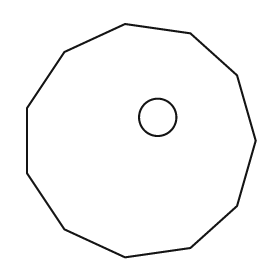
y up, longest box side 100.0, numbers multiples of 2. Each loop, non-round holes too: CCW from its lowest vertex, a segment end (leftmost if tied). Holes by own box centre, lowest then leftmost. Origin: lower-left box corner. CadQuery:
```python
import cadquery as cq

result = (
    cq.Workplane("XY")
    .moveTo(42.0, 0.0)
    .lineTo(70.0, 4.0)
    .lineTo(90.0, 22.0)
    .lineTo(98.0, 50.0)
    .lineTo(90.0, 78.0)
    .lineTo(70.0, 96.0)
    .lineTo(42.0, 100.0)
    .lineTo(16.0, 88.0)
    .lineTo(0.0, 64.0)
    .lineTo(0.0, 36.0)
    .lineTo(16.0, 12.0)
    .close()
    .moveTo(56.0, 60.0)
    .circle(8.0)
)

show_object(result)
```